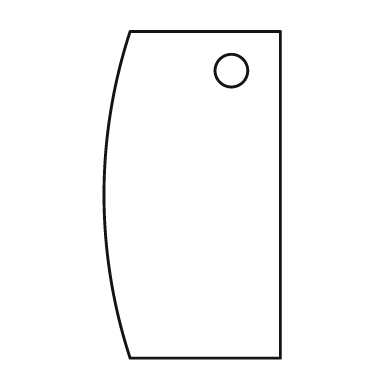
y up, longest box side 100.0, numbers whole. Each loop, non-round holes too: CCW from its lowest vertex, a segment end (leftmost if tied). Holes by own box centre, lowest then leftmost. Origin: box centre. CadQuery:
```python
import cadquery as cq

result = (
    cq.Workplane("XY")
    .moveTo(-19.0, -50.0)
    .lineTo(27.0, -50.0)
    .lineTo(27.0, 50.0)
    .lineTo(-19.0, 50.0)
    .threePointArc((-27.0, 0.0), (-19.0, -50.0))
    .close()
    .moveTo(12.0, 38.0)
    .circle(5.0)
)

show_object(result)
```